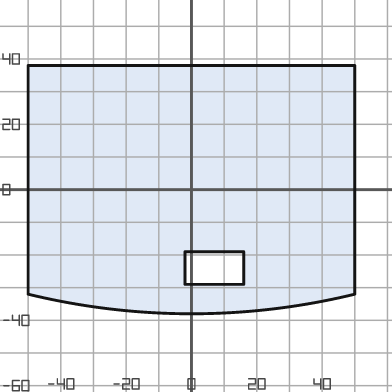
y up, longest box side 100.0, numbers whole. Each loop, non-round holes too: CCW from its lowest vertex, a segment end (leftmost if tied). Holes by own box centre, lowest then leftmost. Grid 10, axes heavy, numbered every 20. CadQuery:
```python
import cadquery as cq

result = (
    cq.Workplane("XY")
    .moveTo(-50.0, -32.0)
    .threePointArc((0.0, -38.0), (50.0, -32.0))
    .lineTo(50.0, 38.0)
    .lineTo(-50.0, 38.0)
    .close()
    .moveTo(-2.0, -29.0)
    .lineTo(16.0, -29.0)
    .lineTo(16.0, -19.0)
    .lineTo(-2.0, -19.0)
    .close()
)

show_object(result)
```